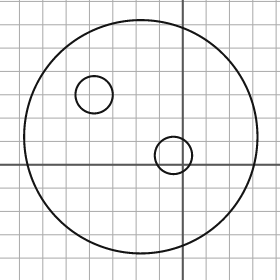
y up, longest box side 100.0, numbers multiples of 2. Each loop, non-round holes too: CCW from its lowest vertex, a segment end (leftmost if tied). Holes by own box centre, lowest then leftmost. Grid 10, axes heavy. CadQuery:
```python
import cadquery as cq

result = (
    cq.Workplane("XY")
    .moveTo(-18.0, 12.0)
    .circle(50.0)
    .moveTo(-4.0, 4.0)
    .circle(8.0)
    .moveTo(-38.0, 30.0)
    .circle(8.0)
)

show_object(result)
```